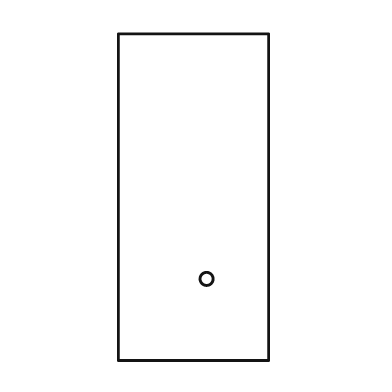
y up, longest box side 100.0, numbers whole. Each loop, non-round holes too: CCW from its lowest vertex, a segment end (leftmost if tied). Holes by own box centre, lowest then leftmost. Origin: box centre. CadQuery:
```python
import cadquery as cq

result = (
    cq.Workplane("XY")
    .moveTo(-23.0, -50.0)
    .lineTo(23.0, -50.0)
    .lineTo(23.0, 50.0)
    .lineTo(-23.0, 50.0)
    .close()
    .moveTo(4.0, -25.0)
    .circle(2.0)
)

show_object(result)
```